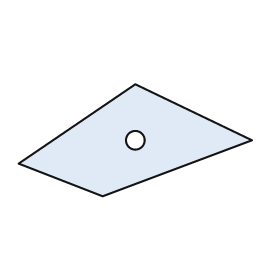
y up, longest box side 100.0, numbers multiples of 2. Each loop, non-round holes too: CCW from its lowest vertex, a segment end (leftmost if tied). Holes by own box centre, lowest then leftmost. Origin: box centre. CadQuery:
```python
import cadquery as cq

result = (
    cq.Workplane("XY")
    .moveTo(-14.0, -24.0)
    .lineTo(50.0, 0.0)
    .lineTo(0.0, 24.0)
    .lineTo(-50.0, -10.0)
    .close()
    .moveTo(0.0, 0.0)
    .circle(4.0)
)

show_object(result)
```